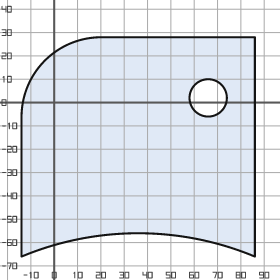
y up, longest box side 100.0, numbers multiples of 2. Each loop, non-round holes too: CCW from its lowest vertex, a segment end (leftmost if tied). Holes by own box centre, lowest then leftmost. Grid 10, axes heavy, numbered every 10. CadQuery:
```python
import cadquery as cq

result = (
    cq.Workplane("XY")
    .moveTo(-14.0, -66.0)
    .threePointArc((36.0, -56.0), (86.0, -66.0))
    .lineTo(86.0, 28.0)
    .lineTo(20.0, 28.0)
    .threePointArc((-4.0, 18.0), (-14.0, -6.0))
    .close()
    .moveTo(66.0, 2.0)
    .circle(8.0)
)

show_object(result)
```